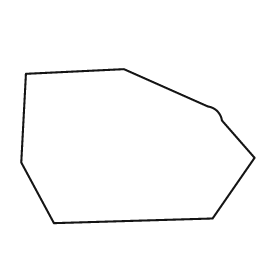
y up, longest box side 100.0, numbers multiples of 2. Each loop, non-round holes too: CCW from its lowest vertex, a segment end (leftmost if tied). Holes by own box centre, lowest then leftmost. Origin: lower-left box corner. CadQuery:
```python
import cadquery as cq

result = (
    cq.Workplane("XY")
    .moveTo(14.0, 0.0)
    .lineTo(82.0, 2.0)
    .lineTo(100.0, 28.0)
    .lineTo(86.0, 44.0)
    .threePointArc((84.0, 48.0), (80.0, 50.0))
    .lineTo(44.0, 66.0)
    .lineTo(2.0, 64.0)
    .lineTo(0.0, 26.0)
    .close()
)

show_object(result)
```